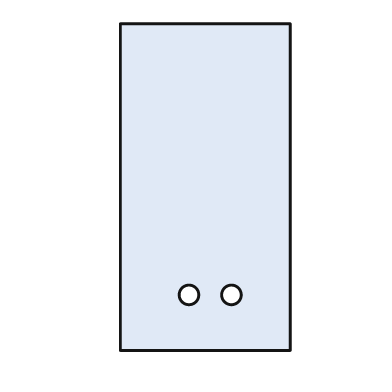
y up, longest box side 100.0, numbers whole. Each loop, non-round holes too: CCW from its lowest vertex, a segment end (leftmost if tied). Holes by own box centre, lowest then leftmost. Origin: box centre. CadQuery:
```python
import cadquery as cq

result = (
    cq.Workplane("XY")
    .moveTo(-26.0, -50.0)
    .lineTo(26.0, -50.0)
    .lineTo(26.0, 50.0)
    .lineTo(-26.0, 50.0)
    .close()
    .moveTo(-5.0, -33.0)
    .circle(3.0)
    .moveTo(8.0, -33.0)
    .circle(3.0)
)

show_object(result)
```